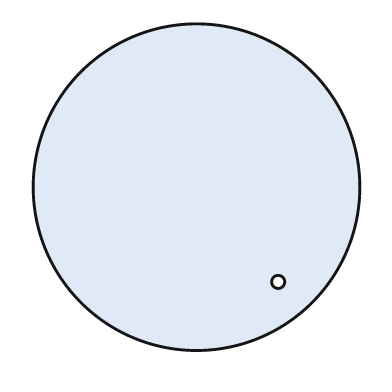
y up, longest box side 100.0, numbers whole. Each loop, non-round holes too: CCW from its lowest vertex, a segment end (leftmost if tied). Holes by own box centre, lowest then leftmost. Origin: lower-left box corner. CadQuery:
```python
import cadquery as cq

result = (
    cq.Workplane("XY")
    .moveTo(50.0, 50.0)
    .circle(50.0)
    .moveTo(75.0, 21.0)
    .circle(2.0)
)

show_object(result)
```